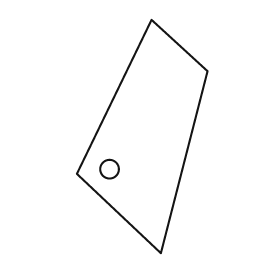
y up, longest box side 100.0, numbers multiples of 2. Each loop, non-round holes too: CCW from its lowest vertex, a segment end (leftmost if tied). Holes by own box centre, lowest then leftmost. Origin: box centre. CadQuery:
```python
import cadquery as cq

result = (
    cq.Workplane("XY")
    .moveTo(8.0, -50.0)
    .lineTo(28.0, 28.0)
    .lineTo(4.0, 50.0)
    .lineTo(-28.0, -16.0)
    .close()
    .moveTo(-14.0, -14.0)
    .circle(4.0)
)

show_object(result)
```